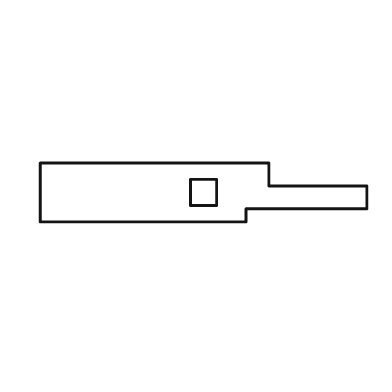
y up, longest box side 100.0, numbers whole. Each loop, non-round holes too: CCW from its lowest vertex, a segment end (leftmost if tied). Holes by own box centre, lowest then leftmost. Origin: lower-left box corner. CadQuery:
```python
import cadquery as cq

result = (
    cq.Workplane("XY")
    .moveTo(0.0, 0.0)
    .lineTo(63.0, 0.0)
    .lineTo(63.0, 4.0)
    .lineTo(100.0, 4.0)
    .lineTo(100.0, 11.0)
    .lineTo(70.0, 11.0)
    .lineTo(70.0, 18.0)
    .lineTo(0.0, 18.0)
    .close()
    .moveTo(46.0, 5.0)
    .lineTo(54.0, 5.0)
    .lineTo(54.0, 13.0)
    .lineTo(46.0, 13.0)
    .close()
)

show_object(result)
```